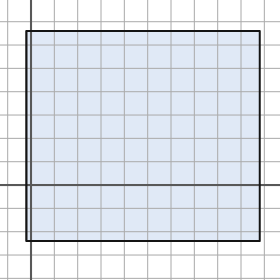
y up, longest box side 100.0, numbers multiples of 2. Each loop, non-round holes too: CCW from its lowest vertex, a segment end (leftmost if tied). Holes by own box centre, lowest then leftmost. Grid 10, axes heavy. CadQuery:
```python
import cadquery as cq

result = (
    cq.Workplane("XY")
    .moveTo(-2.0, -24.0)
    .lineTo(98.0, -24.0)
    .lineTo(98.0, 66.0)
    .lineTo(-2.0, 66.0)
    .close()
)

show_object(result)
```